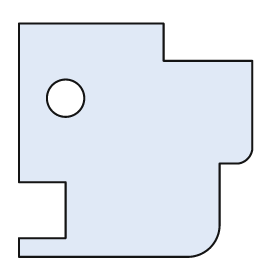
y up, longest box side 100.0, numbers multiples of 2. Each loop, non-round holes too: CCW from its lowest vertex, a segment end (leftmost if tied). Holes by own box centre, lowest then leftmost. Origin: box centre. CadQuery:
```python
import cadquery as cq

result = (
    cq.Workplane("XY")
    .moveTo(-50.0, -50.0)
    .lineTo(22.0, -50.0)
    .threePointArc((32.0, -46.0), (36.0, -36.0))
    .lineTo(36.0, -10.0)
    .lineTo(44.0, -10.0)
    .threePointArc((48.0, -8.0), (50.0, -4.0))
    .lineTo(50.0, 34.0)
    .lineTo(12.0, 34.0)
    .lineTo(12.0, 50.0)
    .lineTo(-50.0, 50.0)
    .lineTo(-50.0, -18.0)
    .lineTo(-30.0, -18.0)
    .lineTo(-30.0, -42.0)
    .lineTo(-50.0, -42.0)
    .close()
    .moveTo(-30.0, 18.0)
    .circle(8.0)
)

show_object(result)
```